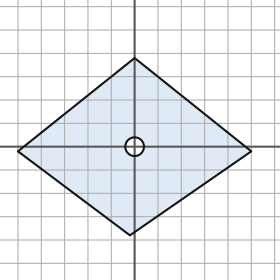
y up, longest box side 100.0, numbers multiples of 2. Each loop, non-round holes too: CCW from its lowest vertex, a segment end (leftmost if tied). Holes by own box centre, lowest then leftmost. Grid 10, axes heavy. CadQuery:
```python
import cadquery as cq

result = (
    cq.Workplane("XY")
    .moveTo(-2.0, -38.0)
    .lineTo(50.0, -2.0)
    .lineTo(0.0, 38.0)
    .lineTo(-50.0, -2.0)
    .close()
    .moveTo(0.0, 0.0)
    .circle(4.0)
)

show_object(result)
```